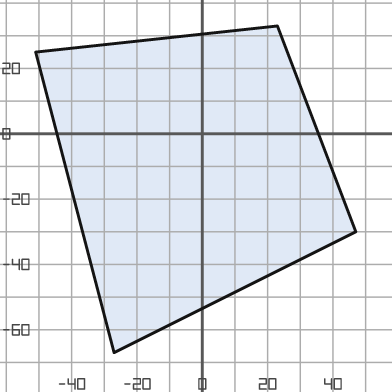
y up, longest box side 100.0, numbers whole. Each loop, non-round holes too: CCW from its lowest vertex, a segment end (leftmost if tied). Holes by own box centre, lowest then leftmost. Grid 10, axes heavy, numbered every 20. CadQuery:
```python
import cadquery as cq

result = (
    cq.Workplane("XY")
    .moveTo(-27.0, -67.0)
    .lineTo(47.0, -30.0)
    .lineTo(23.0, 33.0)
    .lineTo(-51.0, 25.0)
    .close()
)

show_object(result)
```